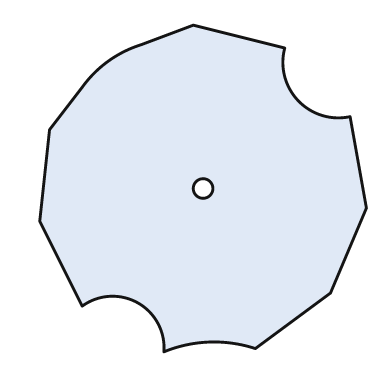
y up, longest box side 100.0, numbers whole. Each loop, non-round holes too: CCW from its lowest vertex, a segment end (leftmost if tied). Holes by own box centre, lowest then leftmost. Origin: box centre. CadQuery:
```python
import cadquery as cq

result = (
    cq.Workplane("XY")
    .moveTo(-12.0, -50.0)
    .threePointArc((2.0, -47.0), (16.0, -49.0))
    .lineTo(39.0, -32.0)
    .lineTo(50.0, -6.0)
    .lineTo(45.0, 22.0)
    .threePointArc((29.0, 27.0), (25.0, 43.0))
    .lineTo(-3.0, 50.0)
    .lineTo(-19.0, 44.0)
    .threePointArc((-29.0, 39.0), (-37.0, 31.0))
    .lineTo(-47.0, 18.0)
    .lineTo(-50.0, -10.0)
    .lineTo(-37.0, -36.0)
    .threePointArc((-20.0, -35.0), (-12.0, -50.0))
    .close()
    .moveTo(0.0, 0.0)
    .circle(3.0)
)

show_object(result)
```